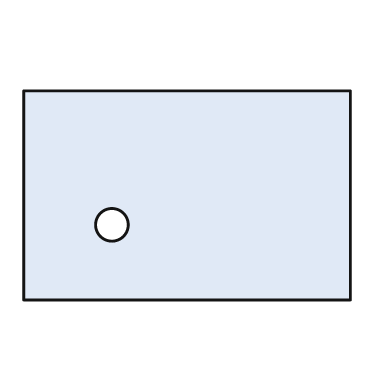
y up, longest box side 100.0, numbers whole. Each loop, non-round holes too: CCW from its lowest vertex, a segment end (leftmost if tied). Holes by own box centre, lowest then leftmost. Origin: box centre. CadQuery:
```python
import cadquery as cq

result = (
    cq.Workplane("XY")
    .moveTo(-50.0, -32.0)
    .lineTo(50.0, -32.0)
    .lineTo(50.0, 32.0)
    .lineTo(-50.0, 32.0)
    .close()
    .moveTo(-23.0, -9.0)
    .circle(5.0)
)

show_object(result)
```